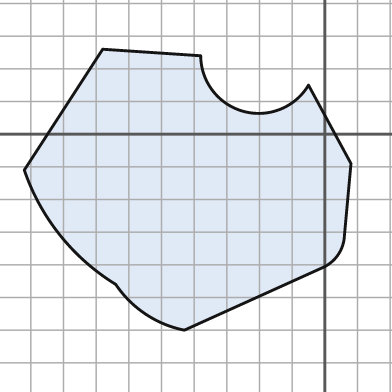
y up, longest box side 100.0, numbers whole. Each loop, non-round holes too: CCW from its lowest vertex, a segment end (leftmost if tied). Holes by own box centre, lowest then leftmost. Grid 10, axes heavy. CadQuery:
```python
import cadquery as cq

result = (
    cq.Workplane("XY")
    .moveTo(-43.0, -60.0)
    .lineTo(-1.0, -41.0)
    .threePointArc((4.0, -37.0), (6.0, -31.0))
    .lineTo(8.0, -9.0)
    .lineTo(-5.0, 15.0)
    .threePointArc((-25.0, 7.0), (-38.0, 24.0))
    .lineTo(-68.0, 26.0)
    .lineTo(-92.0, -11.0)
    .threePointArc((-81.0, -31.0), (-64.0, -46.0))
    .threePointArc((-55.0, -55.0), (-43.0, -60.0))
    .close()
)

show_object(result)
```